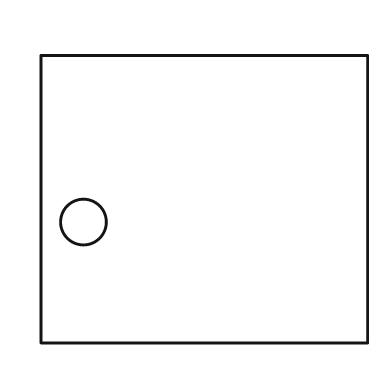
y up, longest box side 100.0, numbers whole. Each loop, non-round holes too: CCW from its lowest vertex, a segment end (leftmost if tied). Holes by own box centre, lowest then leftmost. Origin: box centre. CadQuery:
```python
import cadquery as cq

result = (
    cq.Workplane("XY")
    .moveTo(-50.0, -44.0)
    .lineTo(50.0, -44.0)
    .lineTo(50.0, 44.0)
    .lineTo(-50.0, 44.0)
    .close()
    .moveTo(-37.0, -7.0)
    .circle(7.0)
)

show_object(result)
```